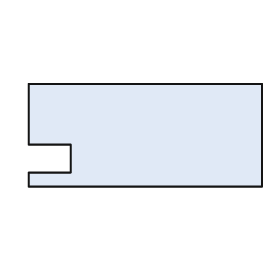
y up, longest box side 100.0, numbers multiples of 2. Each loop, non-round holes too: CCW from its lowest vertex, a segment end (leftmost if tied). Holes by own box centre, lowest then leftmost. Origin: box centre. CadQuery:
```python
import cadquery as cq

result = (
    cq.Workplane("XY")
    .moveTo(-50.0, -22.0)
    .lineTo(50.0, -22.0)
    .lineTo(50.0, 22.0)
    .lineTo(-50.0, 22.0)
    .lineTo(-50.0, -4.0)
    .lineTo(-32.0, -4.0)
    .lineTo(-32.0, -16.0)
    .lineTo(-50.0, -16.0)
    .close()
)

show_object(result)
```